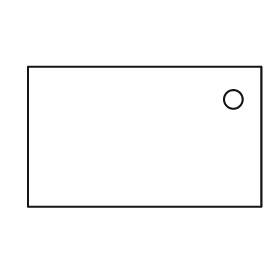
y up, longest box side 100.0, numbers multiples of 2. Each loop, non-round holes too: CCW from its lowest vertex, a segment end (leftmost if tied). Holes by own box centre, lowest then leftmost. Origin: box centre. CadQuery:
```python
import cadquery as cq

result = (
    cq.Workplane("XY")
    .moveTo(-50.0, -30.0)
    .lineTo(50.0, -30.0)
    .lineTo(50.0, 30.0)
    .lineTo(-50.0, 30.0)
    .close()
    .moveTo(38.0, 16.0)
    .circle(4.0)
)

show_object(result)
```